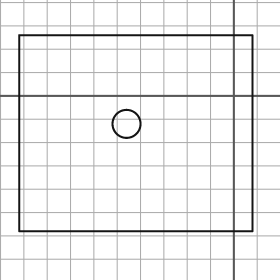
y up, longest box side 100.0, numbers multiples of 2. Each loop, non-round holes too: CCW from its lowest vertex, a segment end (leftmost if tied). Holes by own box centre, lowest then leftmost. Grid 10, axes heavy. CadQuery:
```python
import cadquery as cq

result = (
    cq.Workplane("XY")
    .moveTo(-92.0, -58.0)
    .lineTo(8.0, -58.0)
    .lineTo(8.0, 26.0)
    .lineTo(-92.0, 26.0)
    .close()
    .moveTo(-46.0, -12.0)
    .circle(6.0)
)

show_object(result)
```